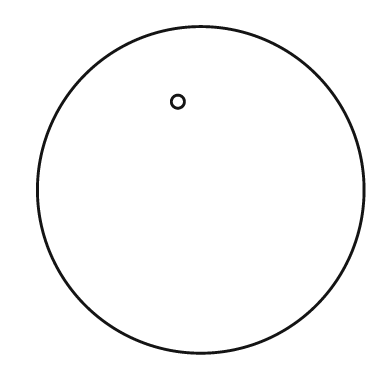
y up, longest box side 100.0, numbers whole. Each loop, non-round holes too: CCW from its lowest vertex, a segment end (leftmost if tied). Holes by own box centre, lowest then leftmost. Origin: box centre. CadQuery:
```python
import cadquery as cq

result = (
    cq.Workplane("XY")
    .moveTo(0.0, 0.0)
    .circle(50.0)
    .moveTo(-7.0, 27.0)
    .circle(2.0)
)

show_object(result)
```